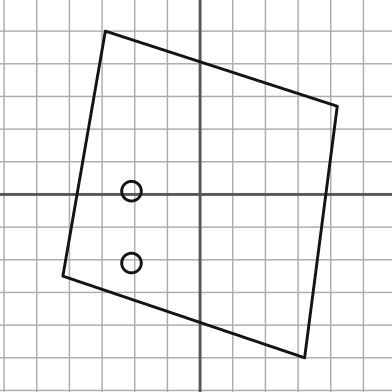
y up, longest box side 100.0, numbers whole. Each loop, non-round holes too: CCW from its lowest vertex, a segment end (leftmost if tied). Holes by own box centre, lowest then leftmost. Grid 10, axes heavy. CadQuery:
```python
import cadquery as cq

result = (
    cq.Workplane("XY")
    .moveTo(32.0, -50.0)
    .lineTo(42.0, 27.0)
    .lineTo(-29.0, 50.0)
    .lineTo(-42.0, -25.0)
    .close()
    .moveTo(-21.0, -21.0)
    .circle(3.0)
    .moveTo(-21.0, 1.0)
    .circle(3.0)
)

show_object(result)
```